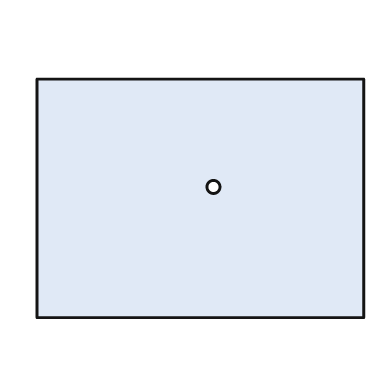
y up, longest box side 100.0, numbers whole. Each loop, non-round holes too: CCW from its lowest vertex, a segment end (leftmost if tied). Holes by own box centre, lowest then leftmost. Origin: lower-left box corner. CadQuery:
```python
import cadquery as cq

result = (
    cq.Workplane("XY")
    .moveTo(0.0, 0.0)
    .lineTo(100.0, 0.0)
    .lineTo(100.0, 73.0)
    .lineTo(0.0, 73.0)
    .close()
    .moveTo(54.0, 40.0)
    .circle(2.0)
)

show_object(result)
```